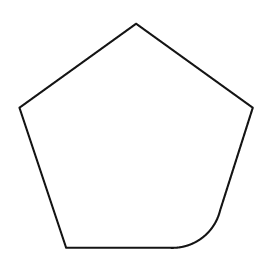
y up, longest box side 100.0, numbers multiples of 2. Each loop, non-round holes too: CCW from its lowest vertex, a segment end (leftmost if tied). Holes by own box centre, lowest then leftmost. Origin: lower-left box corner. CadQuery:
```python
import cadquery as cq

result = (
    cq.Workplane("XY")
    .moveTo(20.0, 0.0)
    .lineTo(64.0, 0.0)
    .threePointArc((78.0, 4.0), (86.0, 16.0))
    .lineTo(100.0, 60.0)
    .lineTo(50.0, 96.0)
    .lineTo(0.0, 60.0)
    .close()
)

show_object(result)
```